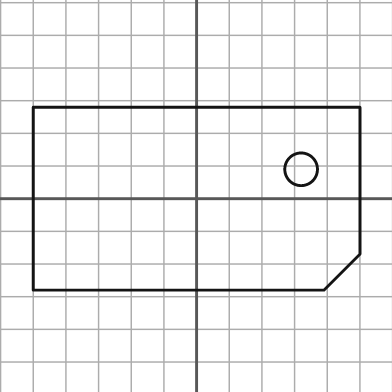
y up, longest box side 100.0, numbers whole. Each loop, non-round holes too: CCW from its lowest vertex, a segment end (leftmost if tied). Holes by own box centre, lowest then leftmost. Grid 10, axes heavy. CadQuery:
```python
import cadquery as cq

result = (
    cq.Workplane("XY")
    .moveTo(-50.0, -28.0)
    .lineTo(39.0, -28.0)
    .lineTo(50.0, -17.0)
    .lineTo(50.0, 28.0)
    .lineTo(-50.0, 28.0)
    .close()
    .moveTo(32.0, 9.0)
    .circle(5.0)
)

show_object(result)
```